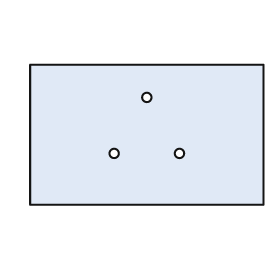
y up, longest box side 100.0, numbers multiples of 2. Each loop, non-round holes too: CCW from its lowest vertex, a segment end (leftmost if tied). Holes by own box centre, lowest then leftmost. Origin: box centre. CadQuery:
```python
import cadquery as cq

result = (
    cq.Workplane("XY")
    .moveTo(-50.0, -30.0)
    .lineTo(50.0, -30.0)
    .lineTo(50.0, 30.0)
    .lineTo(-50.0, 30.0)
    .close()
    .moveTo(-14.0, -8.0)
    .circle(2.0)
    .moveTo(14.0, -8.0)
    .circle(2.0)
    .moveTo(0.0, 16.0)
    .circle(2.0)
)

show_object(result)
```